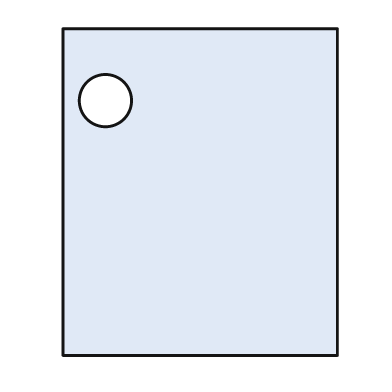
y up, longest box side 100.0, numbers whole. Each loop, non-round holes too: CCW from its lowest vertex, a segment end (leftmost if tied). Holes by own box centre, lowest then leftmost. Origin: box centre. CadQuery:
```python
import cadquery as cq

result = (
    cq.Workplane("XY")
    .moveTo(-42.0, -50.0)
    .lineTo(42.0, -50.0)
    .lineTo(42.0, 50.0)
    .lineTo(-42.0, 50.0)
    .close()
    .moveTo(-29.0, 28.0)
    .circle(8.0)
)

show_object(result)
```